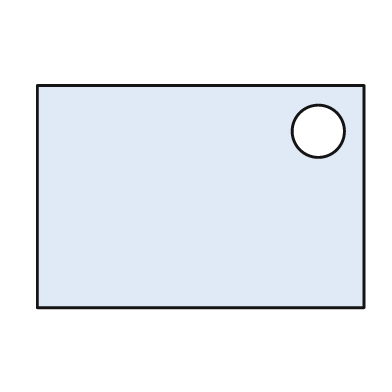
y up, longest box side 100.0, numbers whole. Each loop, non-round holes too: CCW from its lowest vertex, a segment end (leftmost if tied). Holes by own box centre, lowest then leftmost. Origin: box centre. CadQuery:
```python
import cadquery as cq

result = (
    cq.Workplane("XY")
    .moveTo(-50.0, -34.0)
    .lineTo(50.0, -34.0)
    .lineTo(50.0, 34.0)
    .lineTo(-50.0, 34.0)
    .close()
    .moveTo(36.0, 20.0)
    .circle(8.0)
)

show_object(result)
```